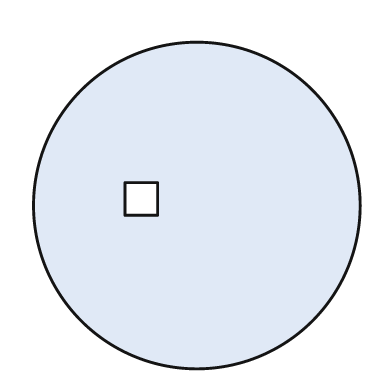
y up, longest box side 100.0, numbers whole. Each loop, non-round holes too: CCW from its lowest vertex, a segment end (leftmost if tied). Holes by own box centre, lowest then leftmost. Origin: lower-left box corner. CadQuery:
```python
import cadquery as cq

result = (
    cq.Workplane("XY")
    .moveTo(50.0, 50.0)
    .circle(50.0)
    .moveTo(28.0, 47.0)
    .lineTo(38.0, 47.0)
    .lineTo(38.0, 57.0)
    .lineTo(28.0, 57.0)
    .close()
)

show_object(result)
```